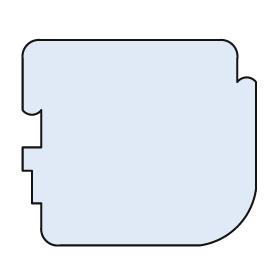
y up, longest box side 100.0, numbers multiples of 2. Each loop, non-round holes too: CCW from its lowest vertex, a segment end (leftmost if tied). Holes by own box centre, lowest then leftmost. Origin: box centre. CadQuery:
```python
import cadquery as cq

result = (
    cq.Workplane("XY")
    .moveTo(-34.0, -44.0)
    .lineTo(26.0, -44.0)
    .threePointArc((42.0, -36.0), (50.0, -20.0))
    .lineTo(50.0, 26.0)
    .threePointArc((46.0, 28.0), (42.0, 26.0))
    .lineTo(42.0, 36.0)
    .threePointArc((40.0, 42.0), (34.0, 44.0))
    .lineTo(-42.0, 44.0)
    .threePointArc((-48.0, 42.0), (-50.0, 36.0))
    .lineTo(-50.0, 14.0)
    .threePointArc((-46.0, 12.0), (-42.0, 14.0))
    .lineTo(-42.0, -2.0)
    .lineTo(-50.0, -2.0)
    .lineTo(-50.0, -12.0)
    .lineTo(-46.0, -12.0)
    .lineTo(-46.0, -26.0)
    .lineTo(-42.0, -26.0)
    .lineTo(-42.0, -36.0)
    .threePointArc((-40.0, -42.0), (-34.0, -44.0))
    .close()
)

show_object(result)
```